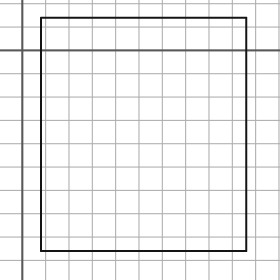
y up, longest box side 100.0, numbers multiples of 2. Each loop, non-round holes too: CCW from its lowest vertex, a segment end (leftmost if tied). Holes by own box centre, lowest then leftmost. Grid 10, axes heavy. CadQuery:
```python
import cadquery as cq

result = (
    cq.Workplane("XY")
    .moveTo(8.0, -86.0)
    .lineTo(96.0, -86.0)
    .lineTo(96.0, 14.0)
    .lineTo(8.0, 14.0)
    .close()
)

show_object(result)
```